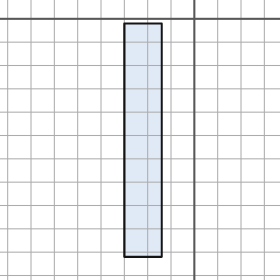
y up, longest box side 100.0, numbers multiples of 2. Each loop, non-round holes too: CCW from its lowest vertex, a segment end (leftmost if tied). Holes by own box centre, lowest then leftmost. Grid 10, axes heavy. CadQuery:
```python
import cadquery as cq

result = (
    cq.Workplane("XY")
    .moveTo(-30.0, -102.0)
    .lineTo(-14.0, -102.0)
    .lineTo(-14.0, -2.0)
    .lineTo(-30.0, -2.0)
    .close()
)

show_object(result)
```